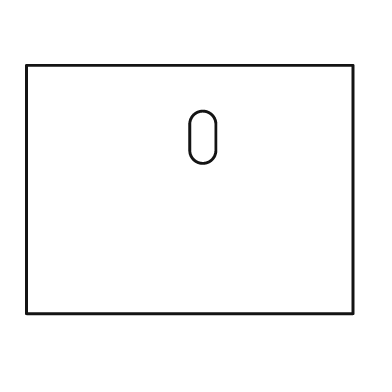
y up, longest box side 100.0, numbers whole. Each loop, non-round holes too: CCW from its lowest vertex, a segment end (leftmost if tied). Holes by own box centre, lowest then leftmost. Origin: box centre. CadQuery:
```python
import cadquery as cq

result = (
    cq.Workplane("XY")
    .moveTo(-50.0, -38.0)
    .lineTo(50.0, -38.0)
    .lineTo(50.0, 38.0)
    .lineTo(-50.0, 38.0)
    .close()
    .moveTo(0.0, 12.0)
    .threePointArc((4.0, 8.0), (8.0, 12.0))
    .lineTo(8.0, 20.0)
    .threePointArc((4.0, 24.0), (0.0, 20.0))
    .close()
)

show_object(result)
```